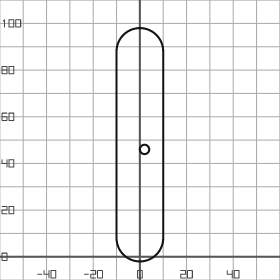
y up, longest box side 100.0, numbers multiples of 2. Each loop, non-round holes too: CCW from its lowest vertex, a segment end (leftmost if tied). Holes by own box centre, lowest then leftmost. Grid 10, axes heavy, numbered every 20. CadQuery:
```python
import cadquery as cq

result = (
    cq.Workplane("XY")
    .moveTo(-10.0, 8.0)
    .threePointArc((0.0, -2.0), (10.0, 8.0))
    .lineTo(10.0, 88.0)
    .threePointArc((0.0, 98.0), (-10.0, 88.0))
    .close()
    .moveTo(2.0, 46.0)
    .circle(2.0)
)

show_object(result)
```